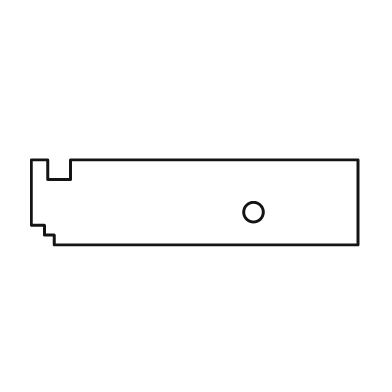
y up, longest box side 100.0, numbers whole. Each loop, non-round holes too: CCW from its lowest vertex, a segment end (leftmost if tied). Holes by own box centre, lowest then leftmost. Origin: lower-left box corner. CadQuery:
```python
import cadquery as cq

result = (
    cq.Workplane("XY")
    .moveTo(7.0, 0.0)
    .lineTo(100.0, 0.0)
    .lineTo(100.0, 26.0)
    .lineTo(12.0, 26.0)
    .lineTo(12.0, 20.0)
    .lineTo(5.0, 20.0)
    .lineTo(5.0, 26.0)
    .lineTo(0.0, 26.0)
    .lineTo(0.0, 6.0)
    .lineTo(4.0, 6.0)
    .lineTo(4.0, 3.0)
    .lineTo(7.0, 3.0)
    .close()
    .moveTo(68.0, 10.0)
    .circle(3.0)
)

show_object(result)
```